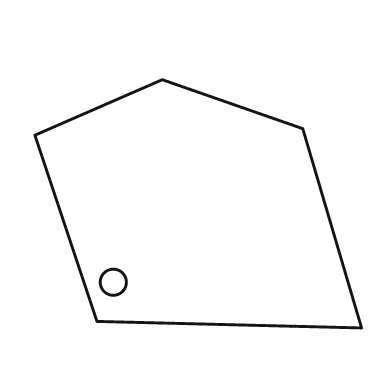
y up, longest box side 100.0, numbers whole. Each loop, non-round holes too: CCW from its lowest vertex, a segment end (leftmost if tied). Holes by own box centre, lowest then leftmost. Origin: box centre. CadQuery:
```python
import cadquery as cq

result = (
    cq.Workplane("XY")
    .moveTo(50.0, -38.0)
    .lineTo(32.0, 23.0)
    .lineTo(-11.0, 38.0)
    .lineTo(-50.0, 21.0)
    .lineTo(-31.0, -36.0)
    .close()
    .moveTo(-26.0, -24.0)
    .circle(4.0)
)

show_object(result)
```